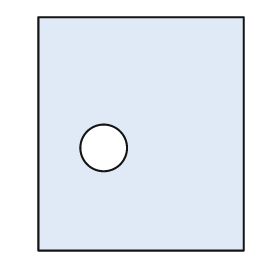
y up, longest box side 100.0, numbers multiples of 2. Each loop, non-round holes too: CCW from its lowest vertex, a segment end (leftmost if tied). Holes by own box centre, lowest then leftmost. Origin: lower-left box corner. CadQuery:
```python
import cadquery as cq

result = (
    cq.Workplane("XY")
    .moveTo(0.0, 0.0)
    .lineTo(88.0, 0.0)
    .lineTo(88.0, 100.0)
    .lineTo(0.0, 100.0)
    .close()
    .moveTo(28.0, 44.0)
    .circle(10.0)
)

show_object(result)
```